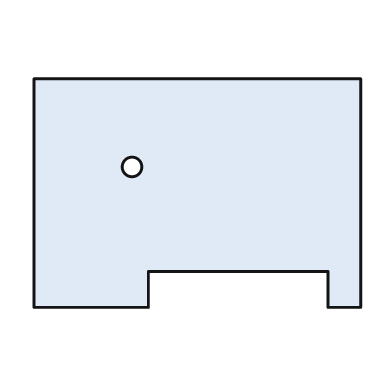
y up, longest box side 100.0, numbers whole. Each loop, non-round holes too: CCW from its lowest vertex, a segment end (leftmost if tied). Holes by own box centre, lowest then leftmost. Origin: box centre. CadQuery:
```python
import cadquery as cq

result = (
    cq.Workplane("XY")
    .moveTo(-50.0, -35.0)
    .lineTo(-15.0, -35.0)
    .lineTo(-15.0, -24.0)
    .lineTo(40.0, -24.0)
    .lineTo(40.0, -35.0)
    .lineTo(50.0, -35.0)
    .lineTo(50.0, 35.0)
    .lineTo(-50.0, 35.0)
    .close()
    .moveTo(-20.0, 8.0)
    .circle(3.0)
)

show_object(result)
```